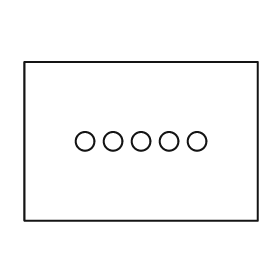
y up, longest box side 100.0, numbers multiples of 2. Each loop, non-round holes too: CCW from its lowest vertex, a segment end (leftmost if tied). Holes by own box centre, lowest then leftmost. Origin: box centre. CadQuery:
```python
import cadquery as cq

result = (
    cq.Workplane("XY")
    .moveTo(-50.0, -34.0)
    .lineTo(50.0, -34.0)
    .lineTo(50.0, 34.0)
    .lineTo(-50.0, 34.0)
    .close()
    .moveTo(-24.0, 0.0)
    .circle(4.0)
    .moveTo(-12.0, 0.0)
    .circle(4.0)
    .moveTo(0.0, 0.0)
    .circle(4.0)
    .moveTo(12.0, 0.0)
    .circle(4.0)
    .moveTo(24.0, 0.0)
    .circle(4.0)
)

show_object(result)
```